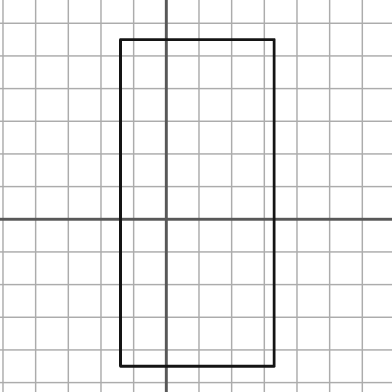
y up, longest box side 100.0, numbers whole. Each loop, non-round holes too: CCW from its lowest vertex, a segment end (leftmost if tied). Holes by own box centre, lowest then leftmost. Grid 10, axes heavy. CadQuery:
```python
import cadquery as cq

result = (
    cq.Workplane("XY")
    .moveTo(-14.0, -45.0)
    .lineTo(33.0, -45.0)
    .lineTo(33.0, 55.0)
    .lineTo(-14.0, 55.0)
    .close()
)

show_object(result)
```